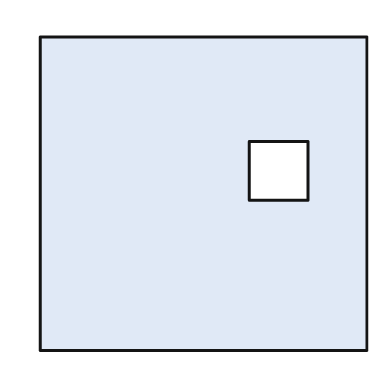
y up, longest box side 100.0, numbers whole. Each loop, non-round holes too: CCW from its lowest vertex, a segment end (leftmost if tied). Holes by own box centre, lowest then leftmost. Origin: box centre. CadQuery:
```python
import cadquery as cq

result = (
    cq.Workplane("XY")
    .moveTo(-50.0, -48.0)
    .lineTo(50.0, -48.0)
    .lineTo(50.0, 48.0)
    .lineTo(-50.0, 48.0)
    .close()
    .moveTo(14.0, -2.0)
    .lineTo(32.0, -2.0)
    .lineTo(32.0, 16.0)
    .lineTo(14.0, 16.0)
    .close()
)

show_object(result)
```